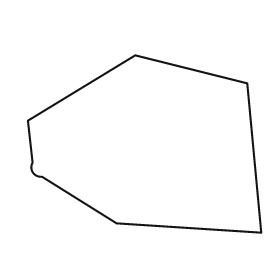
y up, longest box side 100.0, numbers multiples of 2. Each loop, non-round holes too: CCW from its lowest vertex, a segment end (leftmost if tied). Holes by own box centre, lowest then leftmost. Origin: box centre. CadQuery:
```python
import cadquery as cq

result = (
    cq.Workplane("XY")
    .moveTo(50.0, -38.0)
    .lineTo(44.0, 26.0)
    .lineTo(-4.0, 38.0)
    .lineTo(-50.0, 10.0)
    .lineTo(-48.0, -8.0)
    .threePointArc((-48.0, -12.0), (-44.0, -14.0))
    .lineTo(-12.0, -34.0)
    .close()
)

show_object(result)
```